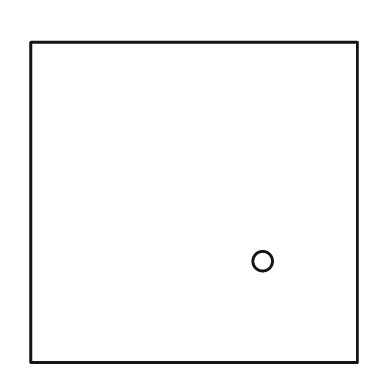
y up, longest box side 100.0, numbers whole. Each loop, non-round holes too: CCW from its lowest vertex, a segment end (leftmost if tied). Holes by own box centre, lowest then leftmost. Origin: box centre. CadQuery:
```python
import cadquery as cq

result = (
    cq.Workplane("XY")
    .moveTo(-50.0, -49.0)
    .lineTo(50.0, -49.0)
    .lineTo(50.0, 49.0)
    .lineTo(-50.0, 49.0)
    .close()
    .moveTo(21.0, -18.0)
    .circle(3.0)
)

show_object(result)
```